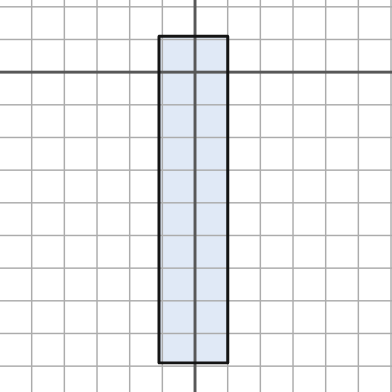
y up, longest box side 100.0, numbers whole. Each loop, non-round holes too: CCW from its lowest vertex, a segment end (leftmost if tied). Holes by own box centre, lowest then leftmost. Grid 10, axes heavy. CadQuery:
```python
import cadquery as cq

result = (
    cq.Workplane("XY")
    .moveTo(-11.0, -89.0)
    .lineTo(10.0, -89.0)
    .lineTo(10.0, 11.0)
    .lineTo(-11.0, 11.0)
    .close()
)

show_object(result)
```